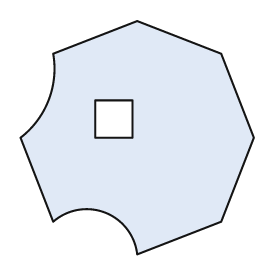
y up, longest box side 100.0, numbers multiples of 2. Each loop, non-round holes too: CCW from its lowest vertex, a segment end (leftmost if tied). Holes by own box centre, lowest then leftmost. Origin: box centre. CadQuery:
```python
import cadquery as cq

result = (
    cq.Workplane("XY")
    .moveTo(0.0, -50.0)
    .lineTo(36.0, -36.0)
    .lineTo(50.0, 0.0)
    .lineTo(36.0, 36.0)
    .lineTo(0.0, 50.0)
    .lineTo(-36.0, 36.0)
    .threePointArc((-38.0, 16.0), (-50.0, 0.0))
    .lineTo(-36.0, -36.0)
    .threePointArc((-14.0, -32.0), (0.0, -50.0))
    .close()
    .moveTo(-18.0, 0.0)
    .lineTo(-2.0, 0.0)
    .lineTo(-2.0, 16.0)
    .lineTo(-18.0, 16.0)
    .close()
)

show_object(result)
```